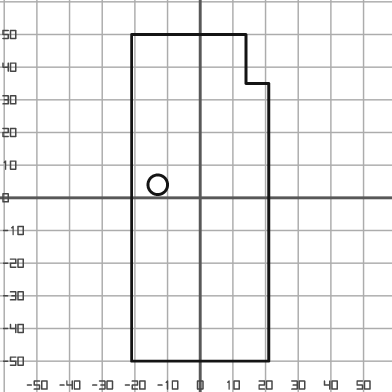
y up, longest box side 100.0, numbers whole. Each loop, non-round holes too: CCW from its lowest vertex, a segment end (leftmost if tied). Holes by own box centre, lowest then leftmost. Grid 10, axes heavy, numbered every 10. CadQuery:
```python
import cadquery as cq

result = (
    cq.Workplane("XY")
    .moveTo(-21.0, -50.0)
    .lineTo(21.0, -50.0)
    .lineTo(21.0, 35.0)
    .lineTo(14.0, 35.0)
    .lineTo(14.0, 50.0)
    .lineTo(-21.0, 50.0)
    .close()
    .moveTo(-13.0, 4.0)
    .circle(3.0)
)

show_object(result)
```